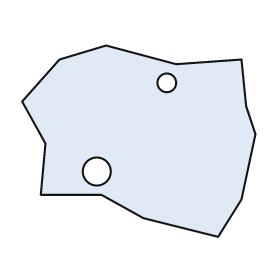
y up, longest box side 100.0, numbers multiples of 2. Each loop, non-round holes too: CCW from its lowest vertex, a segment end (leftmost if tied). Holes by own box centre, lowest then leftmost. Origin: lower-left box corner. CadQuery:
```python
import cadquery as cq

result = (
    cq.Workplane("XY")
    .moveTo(84.0, 0.0)
    .lineTo(94.0, 16.0)
    .lineTo(100.0, 44.0)
    .lineTo(96.0, 56.0)
    .lineTo(94.0, 76.0)
    .lineTo(66.0, 74.0)
    .lineTo(36.0, 82.0)
    .lineTo(16.0, 76.0)
    .lineTo(0.0, 58.0)
    .lineTo(10.0, 40.0)
    .lineTo(8.0, 18.0)
    .lineTo(34.0, 18.0)
    .lineTo(52.0, 8.0)
    .close()
    .moveTo(32.0, 28.0)
    .circle(6.0)
    .moveTo(62.0, 66.0)
    .circle(4.0)
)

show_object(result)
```